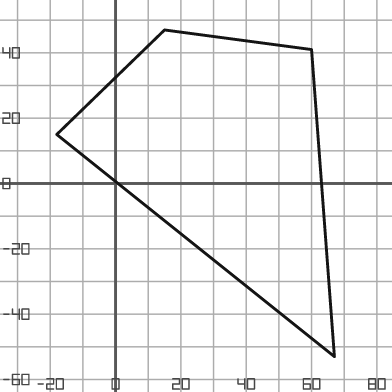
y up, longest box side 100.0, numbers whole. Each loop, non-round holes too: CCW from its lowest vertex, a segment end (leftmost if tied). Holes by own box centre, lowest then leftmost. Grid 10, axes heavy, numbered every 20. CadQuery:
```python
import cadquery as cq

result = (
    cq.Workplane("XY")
    .moveTo(67.0, -53.0)
    .lineTo(60.0, 41.0)
    .lineTo(15.0, 47.0)
    .lineTo(-18.0, 15.0)
    .close()
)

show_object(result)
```